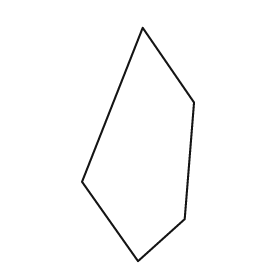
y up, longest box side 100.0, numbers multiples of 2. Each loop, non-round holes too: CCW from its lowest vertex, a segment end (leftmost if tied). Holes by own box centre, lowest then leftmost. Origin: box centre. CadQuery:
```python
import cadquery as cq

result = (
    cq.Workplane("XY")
    .moveTo(0.0, -50.0)
    .lineTo(20.0, -32.0)
    .lineTo(24.0, 18.0)
    .lineTo(2.0, 50.0)
    .lineTo(-24.0, -16.0)
    .close()
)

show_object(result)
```